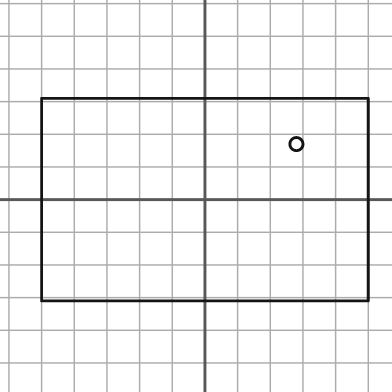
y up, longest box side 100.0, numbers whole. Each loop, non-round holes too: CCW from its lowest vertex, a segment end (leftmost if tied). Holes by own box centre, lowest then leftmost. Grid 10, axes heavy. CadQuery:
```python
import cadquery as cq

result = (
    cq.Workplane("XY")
    .moveTo(-50.0, -31.0)
    .lineTo(50.0, -31.0)
    .lineTo(50.0, 31.0)
    .lineTo(-50.0, 31.0)
    .close()
    .moveTo(28.0, 17.0)
    .circle(2.0)
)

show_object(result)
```